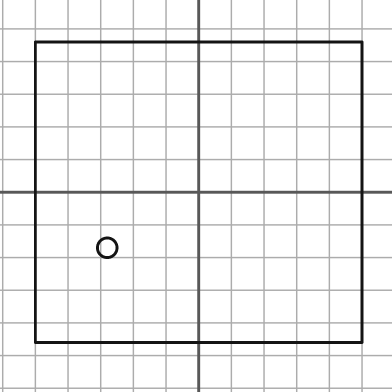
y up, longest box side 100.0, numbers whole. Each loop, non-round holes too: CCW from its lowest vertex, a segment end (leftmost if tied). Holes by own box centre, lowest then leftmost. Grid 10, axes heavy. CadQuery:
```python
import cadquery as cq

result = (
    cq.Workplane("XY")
    .moveTo(-50.0, -46.0)
    .lineTo(50.0, -46.0)
    .lineTo(50.0, 46.0)
    .lineTo(-50.0, 46.0)
    .close()
    .moveTo(-28.0, -17.0)
    .circle(3.0)
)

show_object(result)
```